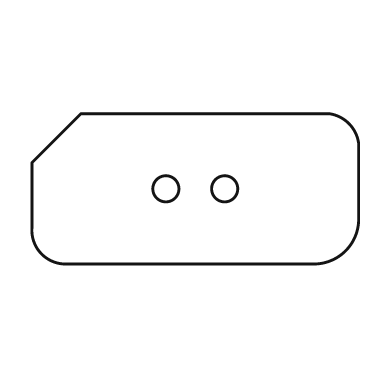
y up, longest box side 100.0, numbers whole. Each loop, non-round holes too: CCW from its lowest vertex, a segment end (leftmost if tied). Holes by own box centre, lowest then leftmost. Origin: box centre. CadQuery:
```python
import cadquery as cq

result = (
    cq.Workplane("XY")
    .moveTo(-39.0, -23.0)
    .lineTo(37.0, -23.0)
    .threePointArc((46.0, -19.0), (50.0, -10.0))
    .lineTo(50.0, 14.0)
    .threePointArc((47.0, 20.0), (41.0, 23.0))
    .lineTo(-35.0, 23.0)
    .lineTo(-50.0, 8.0)
    .lineTo(-50.0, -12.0)
    .threePointArc((-47.0, -20.0), (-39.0, -23.0))
    .close()
    .moveTo(-9.0, 0.0)
    .circle(4.0)
    .moveTo(9.0, 0.0)
    .circle(4.0)
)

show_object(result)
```